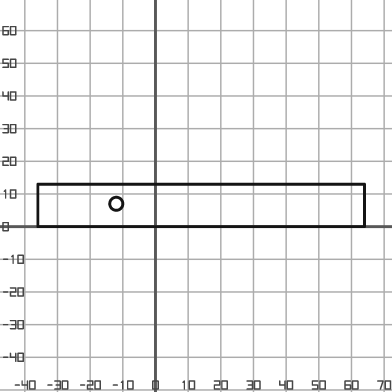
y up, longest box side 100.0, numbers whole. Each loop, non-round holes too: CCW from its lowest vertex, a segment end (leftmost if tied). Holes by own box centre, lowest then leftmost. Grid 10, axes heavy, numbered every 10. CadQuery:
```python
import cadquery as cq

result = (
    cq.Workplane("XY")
    .moveTo(-36.0, 0.0)
    .lineTo(64.0, 0.0)
    .lineTo(64.0, 13.0)
    .lineTo(-36.0, 13.0)
    .close()
    .moveTo(-12.0, 7.0)
    .circle(2.0)
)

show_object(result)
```